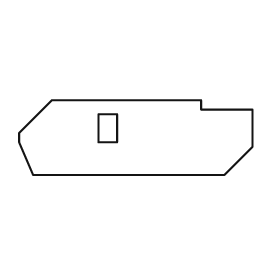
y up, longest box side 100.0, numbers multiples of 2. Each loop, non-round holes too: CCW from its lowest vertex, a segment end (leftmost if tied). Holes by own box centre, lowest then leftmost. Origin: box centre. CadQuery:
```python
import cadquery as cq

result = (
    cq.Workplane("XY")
    .moveTo(-44.0, -16.0)
    .lineTo(38.0, -16.0)
    .lineTo(50.0, -4.0)
    .lineTo(50.0, 12.0)
    .lineTo(28.0, 12.0)
    .lineTo(28.0, 16.0)
    .lineTo(-36.0, 16.0)
    .lineTo(-50.0, 2.0)
    .lineTo(-50.0, -2.0)
    .close()
    .moveTo(-16.0, -2.0)
    .lineTo(-8.0, -2.0)
    .lineTo(-8.0, 10.0)
    .lineTo(-16.0, 10.0)
    .close()
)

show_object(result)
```